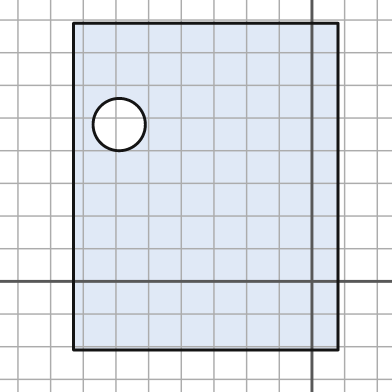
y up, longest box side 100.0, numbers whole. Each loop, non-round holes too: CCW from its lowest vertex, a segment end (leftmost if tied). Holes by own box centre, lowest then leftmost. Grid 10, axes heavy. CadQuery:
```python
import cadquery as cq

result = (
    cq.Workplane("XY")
    .moveTo(-73.0, -21.0)
    .lineTo(8.0, -21.0)
    .lineTo(8.0, 79.0)
    .lineTo(-73.0, 79.0)
    .close()
    .moveTo(-59.0, 48.0)
    .circle(8.0)
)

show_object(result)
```